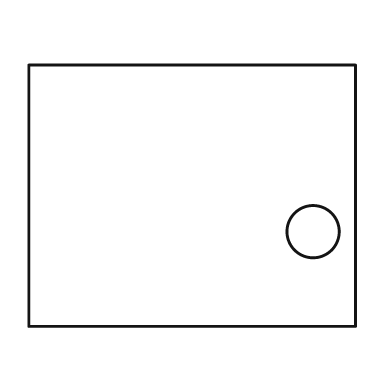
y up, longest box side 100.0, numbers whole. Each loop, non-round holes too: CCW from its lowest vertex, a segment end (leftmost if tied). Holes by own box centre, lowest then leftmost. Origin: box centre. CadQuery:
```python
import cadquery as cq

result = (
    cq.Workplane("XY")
    .moveTo(-50.0, -40.0)
    .lineTo(50.0, -40.0)
    .lineTo(50.0, 40.0)
    .lineTo(-50.0, 40.0)
    .close()
    .moveTo(37.0, -11.0)
    .circle(8.0)
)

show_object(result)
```